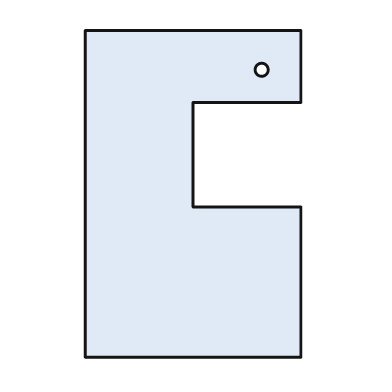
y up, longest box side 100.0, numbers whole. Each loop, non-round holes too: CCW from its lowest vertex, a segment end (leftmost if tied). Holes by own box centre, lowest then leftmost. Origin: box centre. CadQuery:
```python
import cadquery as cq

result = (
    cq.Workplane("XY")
    .moveTo(-33.0, -50.0)
    .lineTo(33.0, -50.0)
    .lineTo(33.0, -4.0)
    .lineTo(0.0, -4.0)
    .lineTo(0.0, 28.0)
    .lineTo(33.0, 28.0)
    .lineTo(33.0, 50.0)
    .lineTo(-33.0, 50.0)
    .close()
    .moveTo(21.0, 38.0)
    .circle(2.0)
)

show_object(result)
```